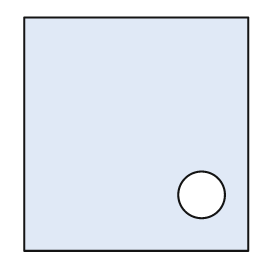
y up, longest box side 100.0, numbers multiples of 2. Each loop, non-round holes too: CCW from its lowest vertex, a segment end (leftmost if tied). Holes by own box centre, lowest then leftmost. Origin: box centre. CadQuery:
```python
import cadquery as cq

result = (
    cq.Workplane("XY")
    .moveTo(-48.0, -50.0)
    .lineTo(48.0, -50.0)
    .lineTo(48.0, 50.0)
    .lineTo(-48.0, 50.0)
    .close()
    .moveTo(28.0, -26.0)
    .circle(10.0)
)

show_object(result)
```